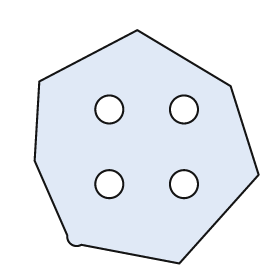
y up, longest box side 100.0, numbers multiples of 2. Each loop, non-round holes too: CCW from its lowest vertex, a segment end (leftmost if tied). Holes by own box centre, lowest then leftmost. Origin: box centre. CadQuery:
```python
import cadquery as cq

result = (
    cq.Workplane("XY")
    .moveTo(14.0, -50.0)
    .lineTo(48.0, -12.0)
    .lineTo(36.0, 26.0)
    .lineTo(-4.0, 50.0)
    .lineTo(-46.0, 28.0)
    .lineTo(-48.0, -6.0)
    .lineTo(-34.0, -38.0)
    .threePointArc((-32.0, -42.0), (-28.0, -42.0))
    .close()
    .moveTo(-16.0, -16.0)
    .circle(6.0)
    .moveTo(16.0, -16.0)
    .circle(6.0)
    .moveTo(-16.0, 16.0)
    .circle(6.0)
    .moveTo(16.0, 16.0)
    .circle(6.0)
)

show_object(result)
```